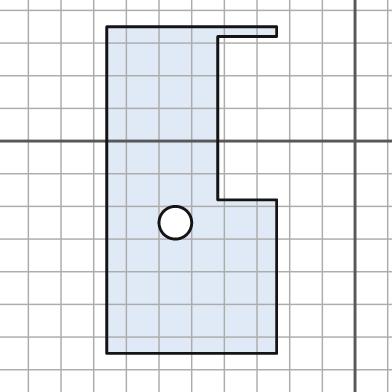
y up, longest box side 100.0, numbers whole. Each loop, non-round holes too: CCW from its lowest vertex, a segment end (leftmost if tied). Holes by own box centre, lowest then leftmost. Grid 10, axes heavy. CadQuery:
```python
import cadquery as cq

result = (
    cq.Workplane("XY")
    .moveTo(-76.0, -65.0)
    .lineTo(-24.0, -65.0)
    .lineTo(-24.0, -18.0)
    .lineTo(-42.0, -18.0)
    .lineTo(-42.0, 32.0)
    .lineTo(-24.0, 32.0)
    .lineTo(-24.0, 35.0)
    .lineTo(-76.0, 35.0)
    .close()
    .moveTo(-55.0, -25.0)
    .circle(5.0)
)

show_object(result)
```